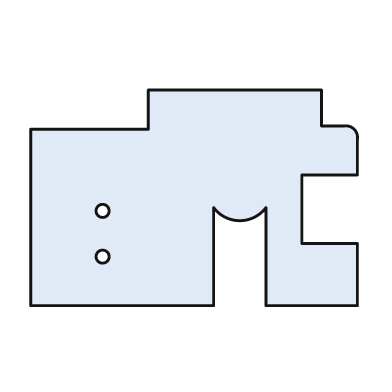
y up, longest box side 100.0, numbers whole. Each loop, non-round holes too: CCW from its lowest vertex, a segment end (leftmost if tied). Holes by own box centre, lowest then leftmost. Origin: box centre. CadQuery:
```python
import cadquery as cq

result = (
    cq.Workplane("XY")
    .moveTo(-50.0, -33.0)
    .lineTo(6.0, -33.0)
    .lineTo(6.0, -3.0)
    .threePointArc((14.0, -7.0), (22.0, -3.0))
    .lineTo(22.0, -33.0)
    .lineTo(50.0, -33.0)
    .lineTo(50.0, -14.0)
    .lineTo(33.0, -14.0)
    .lineTo(33.0, 7.0)
    .lineTo(50.0, 7.0)
    .lineTo(50.0, 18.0)
    .threePointArc((49.0, 21.0), (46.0, 22.0))
    .lineTo(39.0, 22.0)
    .lineTo(39.0, 33.0)
    .lineTo(-14.0, 33.0)
    .lineTo(-14.0, 21.0)
    .lineTo(-50.0, 21.0)
    .close()
    .moveTo(-28.0, -18.0)
    .circle(2.0)
    .moveTo(-28.0, -4.0)
    .circle(2.0)
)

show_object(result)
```